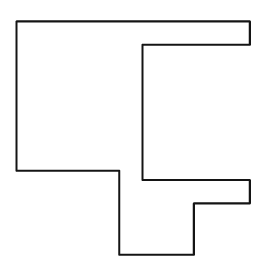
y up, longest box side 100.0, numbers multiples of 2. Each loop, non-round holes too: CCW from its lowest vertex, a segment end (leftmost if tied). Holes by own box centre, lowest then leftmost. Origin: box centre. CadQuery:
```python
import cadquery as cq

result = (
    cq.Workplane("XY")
    .moveTo(-6.0, -50.0)
    .lineTo(26.0, -50.0)
    .lineTo(26.0, -28.0)
    .lineTo(50.0, -28.0)
    .lineTo(50.0, -18.0)
    .lineTo(4.0, -18.0)
    .lineTo(4.0, 40.0)
    .lineTo(50.0, 40.0)
    .lineTo(50.0, 50.0)
    .lineTo(-50.0, 50.0)
    .lineTo(-50.0, -14.0)
    .lineTo(-6.0, -14.0)
    .close()
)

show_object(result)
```